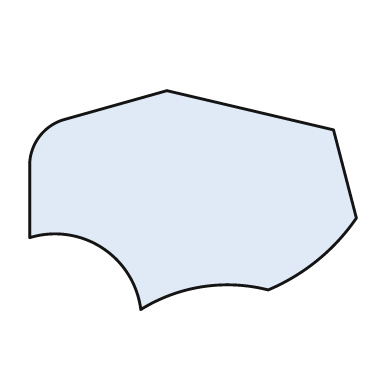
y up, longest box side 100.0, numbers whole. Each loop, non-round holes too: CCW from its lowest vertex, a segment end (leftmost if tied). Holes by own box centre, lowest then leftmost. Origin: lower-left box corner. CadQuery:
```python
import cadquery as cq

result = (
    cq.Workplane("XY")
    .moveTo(34.0, 0.0)
    .threePointArc((53.0, 7.0), (73.0, 6.0))
    .threePointArc((88.0, 15.0), (100.0, 28.0))
    .lineTo(93.0, 55.0)
    .lineTo(42.0, 67.0)
    .lineTo(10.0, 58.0)
    .threePointArc((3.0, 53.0), (0.0, 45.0))
    .lineTo(0.0, 22.0)
    .threePointArc((22.0, 19.0), (34.0, 0.0))
    .close()
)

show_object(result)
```